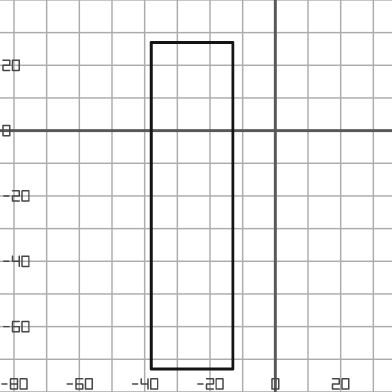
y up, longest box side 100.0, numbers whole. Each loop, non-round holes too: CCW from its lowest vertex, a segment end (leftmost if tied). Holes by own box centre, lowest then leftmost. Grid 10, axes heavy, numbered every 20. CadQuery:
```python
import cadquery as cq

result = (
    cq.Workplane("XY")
    .moveTo(-38.0, -73.0)
    .lineTo(-13.0, -73.0)
    .lineTo(-13.0, 27.0)
    .lineTo(-38.0, 27.0)
    .close()
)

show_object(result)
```